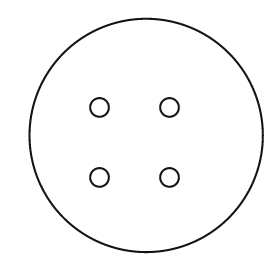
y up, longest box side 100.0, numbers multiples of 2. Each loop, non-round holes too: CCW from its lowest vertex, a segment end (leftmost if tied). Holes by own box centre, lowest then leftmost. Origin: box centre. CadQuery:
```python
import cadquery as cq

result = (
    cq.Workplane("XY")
    .moveTo(0.0, 0.0)
    .circle(50.0)
    .moveTo(-20.0, -18.0)
    .circle(4.0)
    .moveTo(10.0, -18.0)
    .circle(4.0)
    .moveTo(-20.0, 12.0)
    .circle(4.0)
    .moveTo(10.0, 12.0)
    .circle(4.0)
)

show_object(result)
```